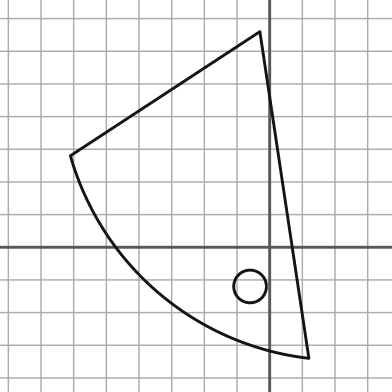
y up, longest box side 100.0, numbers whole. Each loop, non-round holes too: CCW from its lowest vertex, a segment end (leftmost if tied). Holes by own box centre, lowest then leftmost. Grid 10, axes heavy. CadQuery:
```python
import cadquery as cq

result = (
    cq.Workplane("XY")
    .moveTo(12.0, -34.0)
    .lineTo(-3.0, 66.0)
    .lineTo(-61.0, 28.0)
    .threePointArc((-34.0, -14.0), (12.0, -34.0))
    .close()
    .moveTo(-6.0, -12.0)
    .circle(5.0)
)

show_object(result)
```